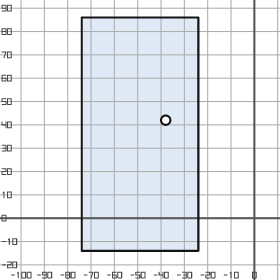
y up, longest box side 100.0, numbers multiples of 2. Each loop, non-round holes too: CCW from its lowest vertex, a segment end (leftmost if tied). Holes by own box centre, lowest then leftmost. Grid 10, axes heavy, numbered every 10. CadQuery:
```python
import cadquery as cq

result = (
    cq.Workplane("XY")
    .moveTo(-74.0, -14.0)
    .lineTo(-24.0, -14.0)
    .lineTo(-24.0, 86.0)
    .lineTo(-74.0, 86.0)
    .close()
    .moveTo(-38.0, 42.0)
    .circle(2.0)
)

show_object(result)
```